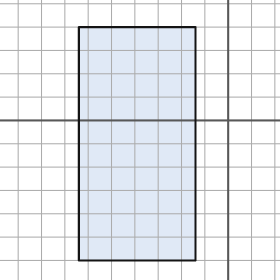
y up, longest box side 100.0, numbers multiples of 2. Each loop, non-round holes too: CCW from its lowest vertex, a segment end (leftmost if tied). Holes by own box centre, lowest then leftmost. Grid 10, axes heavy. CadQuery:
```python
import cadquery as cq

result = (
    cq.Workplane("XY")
    .moveTo(-64.0, -60.0)
    .lineTo(-14.0, -60.0)
    .lineTo(-14.0, 40.0)
    .lineTo(-64.0, 40.0)
    .close()
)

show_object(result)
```